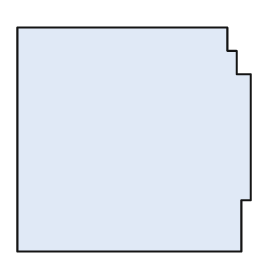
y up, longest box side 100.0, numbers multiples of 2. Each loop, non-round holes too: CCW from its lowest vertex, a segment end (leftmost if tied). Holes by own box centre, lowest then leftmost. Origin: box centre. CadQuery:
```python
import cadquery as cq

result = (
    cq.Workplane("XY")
    .moveTo(-50.0, -48.0)
    .lineTo(46.0, -48.0)
    .lineTo(46.0, -26.0)
    .lineTo(50.0, -26.0)
    .lineTo(50.0, 28.0)
    .lineTo(44.0, 28.0)
    .lineTo(44.0, 38.0)
    .lineTo(40.0, 38.0)
    .lineTo(40.0, 48.0)
    .lineTo(-50.0, 48.0)
    .close()
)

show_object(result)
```